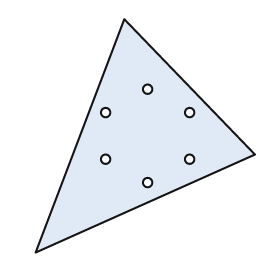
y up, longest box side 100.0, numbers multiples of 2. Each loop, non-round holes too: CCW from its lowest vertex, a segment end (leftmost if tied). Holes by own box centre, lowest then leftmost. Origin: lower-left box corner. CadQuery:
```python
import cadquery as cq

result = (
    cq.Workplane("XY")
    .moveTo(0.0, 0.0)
    .lineTo(94.0, 42.0)
    .lineTo(38.0, 100.0)
    .close()
    .moveTo(48.0, 30.0)
    .circle(2.0)
    .moveTo(30.0, 40.0)
    .circle(2.0)
    .moveTo(66.0, 40.0)
    .circle(2.0)
    .moveTo(30.0, 60.0)
    .circle(2.0)
    .moveTo(66.0, 60.0)
    .circle(2.0)
    .moveTo(48.0, 70.0)
    .circle(2.0)
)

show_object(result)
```